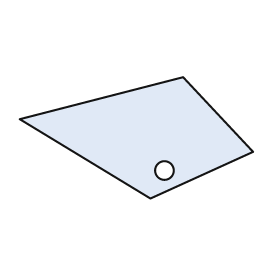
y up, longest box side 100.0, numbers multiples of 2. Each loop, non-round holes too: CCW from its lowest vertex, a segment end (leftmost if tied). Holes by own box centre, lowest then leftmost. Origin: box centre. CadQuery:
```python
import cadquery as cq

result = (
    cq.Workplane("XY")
    .moveTo(6.0, -26.0)
    .lineTo(50.0, -6.0)
    .lineTo(20.0, 26.0)
    .lineTo(-50.0, 8.0)
    .close()
    .moveTo(12.0, -14.0)
    .circle(4.0)
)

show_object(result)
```